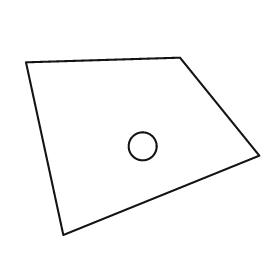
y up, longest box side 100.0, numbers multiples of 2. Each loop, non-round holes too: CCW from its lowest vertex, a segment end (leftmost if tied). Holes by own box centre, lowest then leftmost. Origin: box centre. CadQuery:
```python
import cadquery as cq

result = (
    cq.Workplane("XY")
    .moveTo(-34.0, -38.0)
    .lineTo(50.0, -4.0)
    .lineTo(16.0, 38.0)
    .lineTo(-50.0, 36.0)
    .close()
    .moveTo(0.0, 0.0)
    .circle(6.0)
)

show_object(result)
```